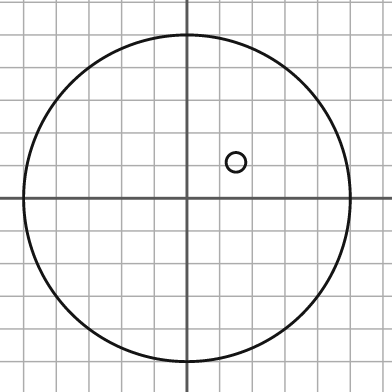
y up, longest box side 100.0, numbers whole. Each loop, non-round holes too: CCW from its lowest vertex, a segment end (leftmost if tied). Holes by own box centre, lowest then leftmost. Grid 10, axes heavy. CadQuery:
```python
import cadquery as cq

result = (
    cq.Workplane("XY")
    .moveTo(0.0, 0.0)
    .circle(50.0)
    .moveTo(15.0, 11.0)
    .circle(3.0)
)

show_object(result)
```